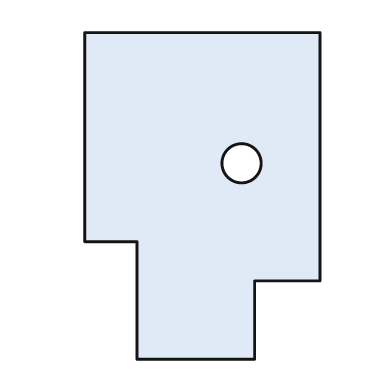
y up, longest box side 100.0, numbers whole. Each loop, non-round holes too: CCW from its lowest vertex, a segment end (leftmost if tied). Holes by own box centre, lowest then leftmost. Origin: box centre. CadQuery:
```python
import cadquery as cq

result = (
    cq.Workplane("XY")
    .moveTo(-20.0, -50.0)
    .lineTo(16.0, -50.0)
    .lineTo(16.0, -26.0)
    .lineTo(36.0, -26.0)
    .lineTo(36.0, 50.0)
    .lineTo(-36.0, 50.0)
    .lineTo(-36.0, -14.0)
    .lineTo(-20.0, -14.0)
    .close()
    .moveTo(12.0, 10.0)
    .circle(6.0)
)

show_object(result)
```